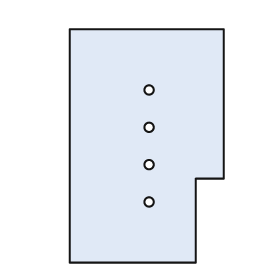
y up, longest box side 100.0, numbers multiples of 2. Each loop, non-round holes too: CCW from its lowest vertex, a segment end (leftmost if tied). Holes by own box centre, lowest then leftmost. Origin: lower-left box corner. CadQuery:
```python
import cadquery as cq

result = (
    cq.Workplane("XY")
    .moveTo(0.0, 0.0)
    .lineTo(54.0, 0.0)
    .lineTo(54.0, 36.0)
    .lineTo(66.0, 36.0)
    .lineTo(66.0, 100.0)
    .lineTo(0.0, 100.0)
    .close()
    .moveTo(34.0, 26.0)
    .circle(2.0)
    .moveTo(34.0, 42.0)
    .circle(2.0)
    .moveTo(34.0, 58.0)
    .circle(2.0)
    .moveTo(34.0, 74.0)
    .circle(2.0)
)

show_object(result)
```